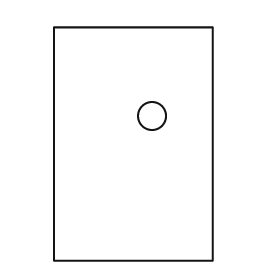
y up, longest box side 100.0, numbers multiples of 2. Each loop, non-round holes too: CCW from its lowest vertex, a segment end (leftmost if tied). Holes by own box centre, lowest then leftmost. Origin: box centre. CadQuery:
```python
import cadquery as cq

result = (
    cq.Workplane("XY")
    .moveTo(-34.0, -50.0)
    .lineTo(34.0, -50.0)
    .lineTo(34.0, 50.0)
    .lineTo(-34.0, 50.0)
    .close()
    .moveTo(8.0, 12.0)
    .circle(6.0)
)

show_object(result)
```